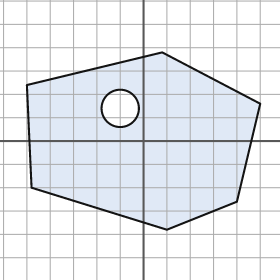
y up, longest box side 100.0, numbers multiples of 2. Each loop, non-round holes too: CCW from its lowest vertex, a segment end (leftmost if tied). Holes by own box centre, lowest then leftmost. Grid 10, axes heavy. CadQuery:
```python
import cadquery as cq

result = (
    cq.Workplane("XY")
    .moveTo(10.0, -38.0)
    .lineTo(40.0, -26.0)
    .lineTo(50.0, 16.0)
    .lineTo(8.0, 38.0)
    .lineTo(-50.0, 24.0)
    .lineTo(-48.0, -20.0)
    .close()
    .moveTo(-10.0, 14.0)
    .circle(8.0)
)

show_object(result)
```